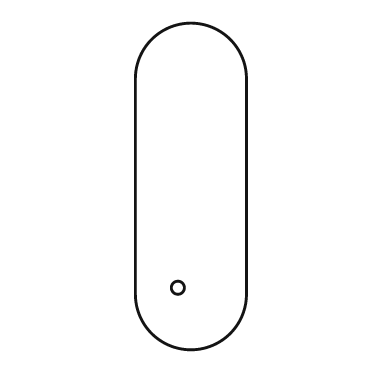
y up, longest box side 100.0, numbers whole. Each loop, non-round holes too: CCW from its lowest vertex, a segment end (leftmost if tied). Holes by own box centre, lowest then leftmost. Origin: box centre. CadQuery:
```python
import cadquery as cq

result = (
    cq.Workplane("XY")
    .moveTo(-17.0, -33.0)
    .threePointArc((0.0, -50.0), (17.0, -33.0))
    .lineTo(17.0, 33.0)
    .threePointArc((0.0, 50.0), (-17.0, 33.0))
    .close()
    .moveTo(-4.0, -31.0)
    .circle(2.0)
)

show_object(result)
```